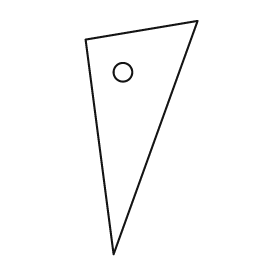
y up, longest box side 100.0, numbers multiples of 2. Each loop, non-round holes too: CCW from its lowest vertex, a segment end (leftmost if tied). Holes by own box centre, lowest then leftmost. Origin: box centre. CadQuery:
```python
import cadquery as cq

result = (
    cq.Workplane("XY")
    .moveTo(-12.0, -50.0)
    .lineTo(24.0, 50.0)
    .lineTo(-24.0, 42.0)
    .close()
    .moveTo(-8.0, 28.0)
    .circle(4.0)
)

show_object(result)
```